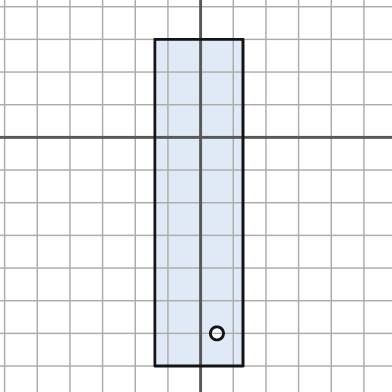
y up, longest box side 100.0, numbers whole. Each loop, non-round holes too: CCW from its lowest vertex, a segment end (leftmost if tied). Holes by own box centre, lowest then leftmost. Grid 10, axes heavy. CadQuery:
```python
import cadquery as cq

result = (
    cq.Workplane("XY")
    .moveTo(-14.0, -70.0)
    .lineTo(13.0, -70.0)
    .lineTo(13.0, 30.0)
    .lineTo(-14.0, 30.0)
    .close()
    .moveTo(5.0, -60.0)
    .circle(2.0)
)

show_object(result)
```